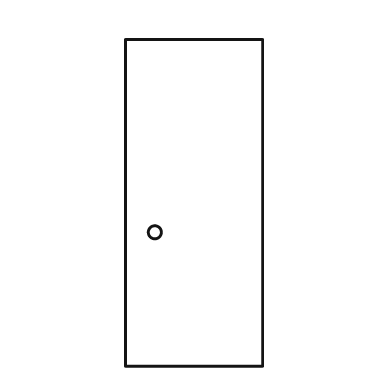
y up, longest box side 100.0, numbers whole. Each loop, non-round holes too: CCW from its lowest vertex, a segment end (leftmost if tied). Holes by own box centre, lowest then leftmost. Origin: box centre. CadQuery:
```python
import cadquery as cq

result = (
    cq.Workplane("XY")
    .moveTo(-21.0, -50.0)
    .lineTo(21.0, -50.0)
    .lineTo(21.0, 50.0)
    .lineTo(-21.0, 50.0)
    .close()
    .moveTo(-12.0, -9.0)
    .circle(2.0)
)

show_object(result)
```